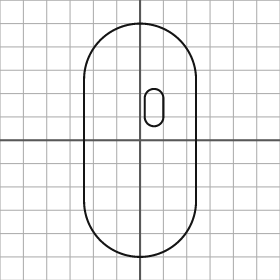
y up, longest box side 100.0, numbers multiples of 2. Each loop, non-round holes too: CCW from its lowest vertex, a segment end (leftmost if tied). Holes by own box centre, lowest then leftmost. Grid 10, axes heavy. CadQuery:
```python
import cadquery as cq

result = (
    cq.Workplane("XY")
    .moveTo(-24.0, -26.0)
    .threePointArc((0.0, -50.0), (24.0, -26.0))
    .lineTo(24.0, 26.0)
    .threePointArc((0.0, 50.0), (-24.0, 26.0))
    .close()
    .moveTo(2.0, 10.0)
    .threePointArc((6.0, 6.0), (10.0, 10.0))
    .lineTo(10.0, 18.0)
    .threePointArc((6.0, 22.0), (2.0, 18.0))
    .close()
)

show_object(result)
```